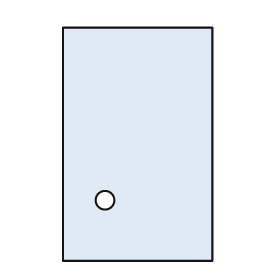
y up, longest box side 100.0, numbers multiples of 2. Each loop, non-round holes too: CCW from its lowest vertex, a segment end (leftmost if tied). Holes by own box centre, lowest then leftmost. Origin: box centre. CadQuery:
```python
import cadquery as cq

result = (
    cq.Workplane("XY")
    .moveTo(-32.0, -50.0)
    .lineTo(32.0, -50.0)
    .lineTo(32.0, 50.0)
    .lineTo(-32.0, 50.0)
    .close()
    .moveTo(-14.0, -24.0)
    .circle(4.0)
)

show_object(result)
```